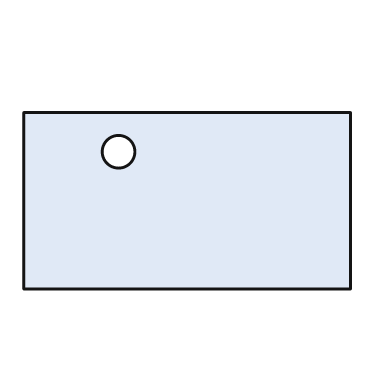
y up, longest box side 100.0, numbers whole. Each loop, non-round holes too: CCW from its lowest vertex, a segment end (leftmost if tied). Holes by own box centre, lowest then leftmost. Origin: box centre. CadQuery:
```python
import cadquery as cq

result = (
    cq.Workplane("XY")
    .moveTo(-50.0, -27.0)
    .lineTo(50.0, -27.0)
    .lineTo(50.0, 27.0)
    .lineTo(-50.0, 27.0)
    .close()
    .moveTo(-21.0, 15.0)
    .circle(5.0)
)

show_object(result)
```